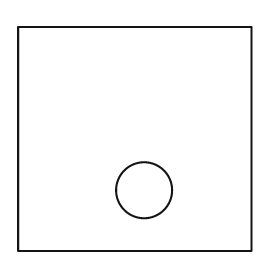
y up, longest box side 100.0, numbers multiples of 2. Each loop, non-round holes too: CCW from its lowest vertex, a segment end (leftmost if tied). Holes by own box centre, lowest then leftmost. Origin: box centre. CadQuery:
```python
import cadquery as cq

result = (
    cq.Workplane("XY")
    .moveTo(-50.0, -48.0)
    .lineTo(50.0, -48.0)
    .lineTo(50.0, 48.0)
    .lineTo(-50.0, 48.0)
    .close()
    .moveTo(4.0, -22.0)
    .circle(12.0)
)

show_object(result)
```